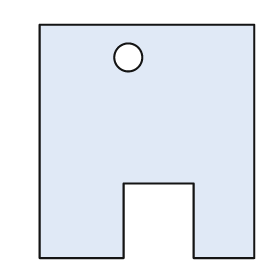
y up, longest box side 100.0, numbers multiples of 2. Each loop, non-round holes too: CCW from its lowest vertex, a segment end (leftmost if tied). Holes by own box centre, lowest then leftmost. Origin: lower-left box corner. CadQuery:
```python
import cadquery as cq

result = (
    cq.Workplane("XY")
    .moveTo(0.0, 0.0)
    .lineTo(36.0, 0.0)
    .lineTo(36.0, 32.0)
    .lineTo(66.0, 32.0)
    .lineTo(66.0, 0.0)
    .lineTo(92.0, 0.0)
    .lineTo(92.0, 100.0)
    .lineTo(0.0, 100.0)
    .close()
    .moveTo(38.0, 86.0)
    .circle(6.0)
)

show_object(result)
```